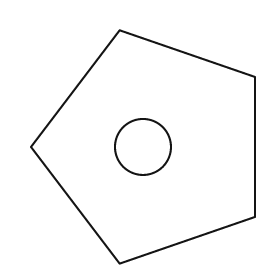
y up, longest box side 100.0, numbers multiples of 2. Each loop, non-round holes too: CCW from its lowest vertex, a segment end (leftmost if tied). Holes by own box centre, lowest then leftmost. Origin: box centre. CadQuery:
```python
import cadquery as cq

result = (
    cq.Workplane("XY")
    .moveTo(-10.0, -50.0)
    .lineTo(48.0, -30.0)
    .lineTo(48.0, 30.0)
    .lineTo(-10.0, 50.0)
    .lineTo(-48.0, 0.0)
    .close()
    .moveTo(0.0, 0.0)
    .circle(12.0)
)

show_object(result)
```